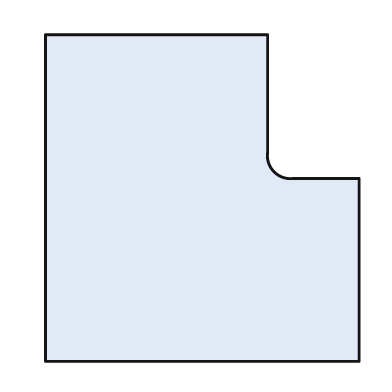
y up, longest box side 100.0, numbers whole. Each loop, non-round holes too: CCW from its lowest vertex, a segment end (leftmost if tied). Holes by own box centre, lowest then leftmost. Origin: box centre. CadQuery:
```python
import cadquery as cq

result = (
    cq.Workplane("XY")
    .moveTo(-48.0, -50.0)
    .lineTo(48.0, -50.0)
    .lineTo(48.0, 6.0)
    .lineTo(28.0, 6.0)
    .threePointArc((22.0, 8.0), (20.0, 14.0))
    .lineTo(20.0, 50.0)
    .lineTo(-48.0, 50.0)
    .close()
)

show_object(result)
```